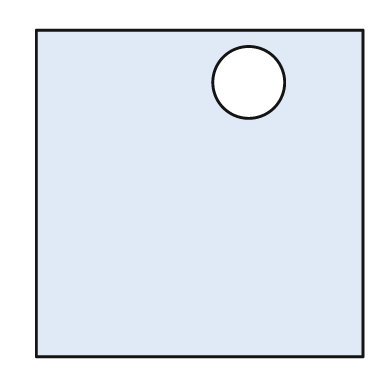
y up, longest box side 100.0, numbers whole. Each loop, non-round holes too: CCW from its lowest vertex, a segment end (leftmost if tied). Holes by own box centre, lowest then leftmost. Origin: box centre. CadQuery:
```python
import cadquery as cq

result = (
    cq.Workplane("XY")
    .moveTo(-50.0, -50.0)
    .lineTo(50.0, -50.0)
    .lineTo(50.0, 50.0)
    .lineTo(-50.0, 50.0)
    .close()
    .moveTo(15.0, 34.0)
    .circle(11.0)
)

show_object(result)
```